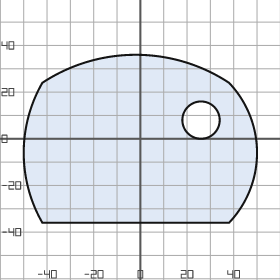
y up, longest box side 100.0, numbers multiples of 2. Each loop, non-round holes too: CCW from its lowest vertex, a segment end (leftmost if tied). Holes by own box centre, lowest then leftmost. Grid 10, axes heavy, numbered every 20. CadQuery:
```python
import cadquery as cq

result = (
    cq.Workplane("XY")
    .moveTo(-42.0, -36.0)
    .lineTo(38.0, -36.0)
    .threePointArc((50.0, -6.0), (38.0, 24.0))
    .threePointArc((-2.0, 36.0), (-42.0, 24.0))
    .threePointArc((-50.0, -6.0), (-42.0, -36.0))
    .close()
    .moveTo(26.0, 8.0)
    .circle(8.0)
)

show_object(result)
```